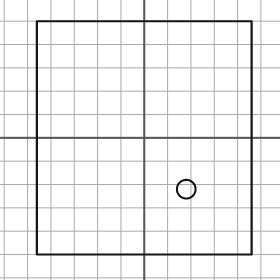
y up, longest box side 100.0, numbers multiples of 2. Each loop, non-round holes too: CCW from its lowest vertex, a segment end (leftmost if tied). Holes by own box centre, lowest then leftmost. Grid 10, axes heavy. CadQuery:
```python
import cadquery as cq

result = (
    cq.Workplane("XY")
    .moveTo(-46.0, -50.0)
    .lineTo(46.0, -50.0)
    .lineTo(46.0, 50.0)
    .lineTo(-46.0, 50.0)
    .close()
    .moveTo(18.0, -22.0)
    .circle(4.0)
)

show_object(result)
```